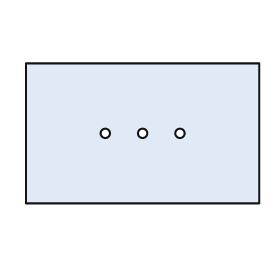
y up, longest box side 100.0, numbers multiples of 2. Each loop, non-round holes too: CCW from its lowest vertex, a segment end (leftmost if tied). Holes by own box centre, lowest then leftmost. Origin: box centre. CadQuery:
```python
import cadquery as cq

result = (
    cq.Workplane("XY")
    .moveTo(-50.0, -30.0)
    .lineTo(50.0, -30.0)
    .lineTo(50.0, 30.0)
    .lineTo(-50.0, 30.0)
    .close()
    .moveTo(-16.0, 0.0)
    .circle(2.0)
    .moveTo(0.0, 0.0)
    .circle(2.0)
    .moveTo(16.0, 0.0)
    .circle(2.0)
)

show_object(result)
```